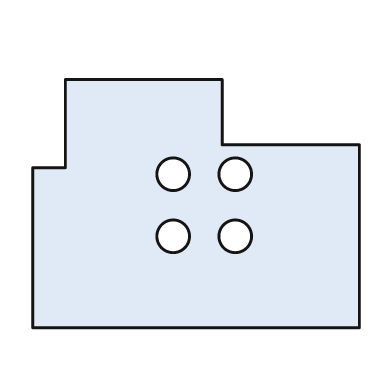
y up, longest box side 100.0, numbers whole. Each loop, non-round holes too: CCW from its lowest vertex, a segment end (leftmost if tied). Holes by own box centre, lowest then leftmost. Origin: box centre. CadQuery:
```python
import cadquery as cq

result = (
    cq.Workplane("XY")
    .moveTo(-50.0, -38.0)
    .lineTo(50.0, -38.0)
    .lineTo(50.0, 18.0)
    .lineTo(8.0, 18.0)
    .lineTo(8.0, 38.0)
    .lineTo(-40.0, 38.0)
    .lineTo(-40.0, 11.0)
    .lineTo(-50.0, 11.0)
    .close()
    .moveTo(-7.0, -10.0)
    .circle(5.0)
    .moveTo(12.0, -10.0)
    .circle(5.0)
    .moveTo(-7.0, 9.0)
    .circle(5.0)
    .moveTo(12.0, 9.0)
    .circle(5.0)
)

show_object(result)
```